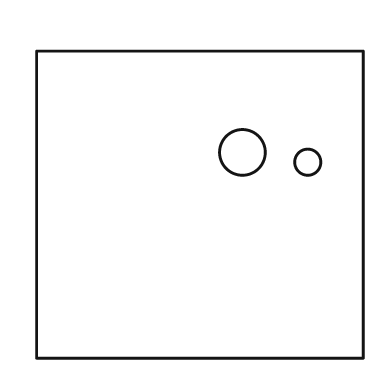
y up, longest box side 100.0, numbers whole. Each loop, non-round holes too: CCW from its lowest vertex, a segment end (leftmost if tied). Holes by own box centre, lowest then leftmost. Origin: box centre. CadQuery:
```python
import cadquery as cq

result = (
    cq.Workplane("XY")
    .moveTo(-50.0, -47.0)
    .lineTo(50.0, -47.0)
    .lineTo(50.0, 47.0)
    .lineTo(-50.0, 47.0)
    .close()
    .moveTo(33.0, 13.0)
    .circle(4.0)
    .moveTo(13.0, 16.0)
    .circle(7.0)
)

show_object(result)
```